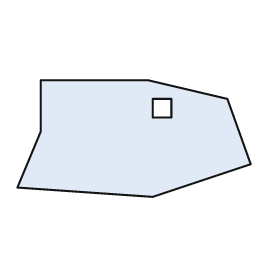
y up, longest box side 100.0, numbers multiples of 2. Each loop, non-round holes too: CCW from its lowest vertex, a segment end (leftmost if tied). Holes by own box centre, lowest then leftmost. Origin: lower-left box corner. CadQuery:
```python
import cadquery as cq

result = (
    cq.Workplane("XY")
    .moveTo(58.0, 0.0)
    .lineTo(100.0, 14.0)
    .lineTo(90.0, 42.0)
    .lineTo(56.0, 50.0)
    .lineTo(10.0, 50.0)
    .lineTo(10.0, 28.0)
    .lineTo(0.0, 4.0)
    .close()
    .moveTo(58.0, 34.0)
    .lineTo(66.0, 34.0)
    .lineTo(66.0, 42.0)
    .lineTo(58.0, 42.0)
    .close()
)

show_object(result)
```